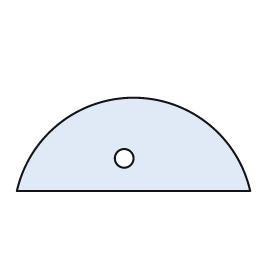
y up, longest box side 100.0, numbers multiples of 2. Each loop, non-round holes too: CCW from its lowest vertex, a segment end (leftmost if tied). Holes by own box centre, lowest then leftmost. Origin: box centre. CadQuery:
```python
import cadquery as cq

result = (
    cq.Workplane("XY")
    .moveTo(-50.0, -20.0)
    .lineTo(50.0, -20.0)
    .threePointArc((0.0, 20.0), (-50.0, -20.0))
    .close()
    .moveTo(-4.0, -6.0)
    .circle(4.0)
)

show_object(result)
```